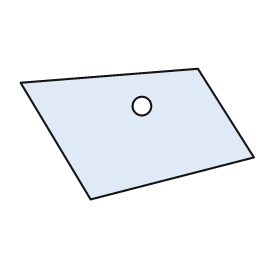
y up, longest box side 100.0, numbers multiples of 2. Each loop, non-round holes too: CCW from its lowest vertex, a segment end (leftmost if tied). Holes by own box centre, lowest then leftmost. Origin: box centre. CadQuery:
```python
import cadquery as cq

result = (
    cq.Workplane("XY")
    .moveTo(-20.0, -28.0)
    .lineTo(50.0, -10.0)
    .lineTo(26.0, 28.0)
    .lineTo(-50.0, 22.0)
    .close()
    .moveTo(2.0, 12.0)
    .circle(4.0)
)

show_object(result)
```